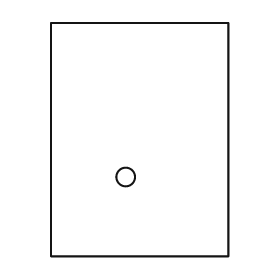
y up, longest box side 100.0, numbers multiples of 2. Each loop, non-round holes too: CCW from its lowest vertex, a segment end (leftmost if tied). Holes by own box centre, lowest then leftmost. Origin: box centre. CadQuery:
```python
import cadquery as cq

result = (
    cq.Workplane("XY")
    .moveTo(-38.0, -50.0)
    .lineTo(38.0, -50.0)
    .lineTo(38.0, 50.0)
    .lineTo(-38.0, 50.0)
    .close()
    .moveTo(-6.0, -16.0)
    .circle(4.0)
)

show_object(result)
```